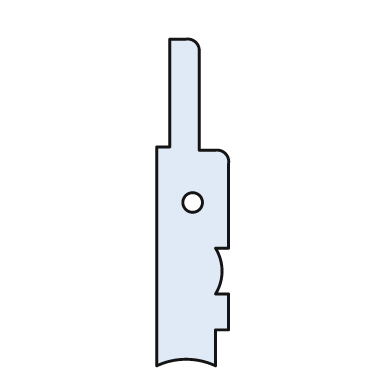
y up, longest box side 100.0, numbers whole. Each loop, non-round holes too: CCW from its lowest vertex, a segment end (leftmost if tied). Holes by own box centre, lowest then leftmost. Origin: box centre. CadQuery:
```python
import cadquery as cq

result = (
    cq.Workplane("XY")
    .moveTo(-11.0, -50.0)
    .threePointArc((-2.0, -48.0), (7.0, -50.0))
    .lineTo(7.0, -39.0)
    .lineTo(11.0, -39.0)
    .lineTo(11.0, -28.0)
    .lineTo(7.0, -28.0)
    .threePointArc((9.0, -21.0), (7.0, -14.0))
    .lineTo(11.0, -14.0)
    .lineTo(11.0, 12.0)
    .threePointArc((10.0, 15.0), (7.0, 16.0))
    .lineTo(2.0, 16.0)
    .lineTo(2.0, 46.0)
    .threePointArc((1.0, 49.0), (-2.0, 50.0))
    .lineTo(-7.0, 50.0)
    .lineTo(-7.0, 17.0)
    .lineTo(-11.0, 17.0)
    .close()
    .moveTo(0.0, 0.0)
    .circle(3.0)
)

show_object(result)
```